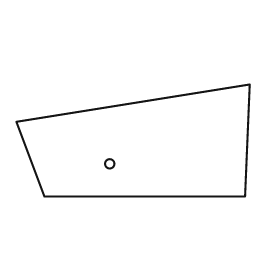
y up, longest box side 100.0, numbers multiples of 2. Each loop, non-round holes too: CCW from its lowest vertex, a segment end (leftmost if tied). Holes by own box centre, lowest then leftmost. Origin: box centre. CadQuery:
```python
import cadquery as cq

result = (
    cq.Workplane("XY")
    .moveTo(-38.0, -24.0)
    .lineTo(48.0, -24.0)
    .lineTo(50.0, 24.0)
    .lineTo(-50.0, 8.0)
    .close()
    .moveTo(-10.0, -10.0)
    .circle(2.0)
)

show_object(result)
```